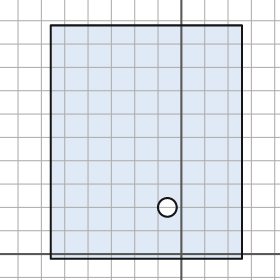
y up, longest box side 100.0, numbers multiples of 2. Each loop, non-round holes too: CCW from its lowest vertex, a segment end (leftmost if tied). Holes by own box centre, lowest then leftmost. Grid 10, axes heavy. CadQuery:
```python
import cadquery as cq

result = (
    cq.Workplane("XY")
    .moveTo(-56.0, -2.0)
    .lineTo(26.0, -2.0)
    .lineTo(26.0, 98.0)
    .lineTo(-56.0, 98.0)
    .close()
    .moveTo(-6.0, 20.0)
    .circle(4.0)
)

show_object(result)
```